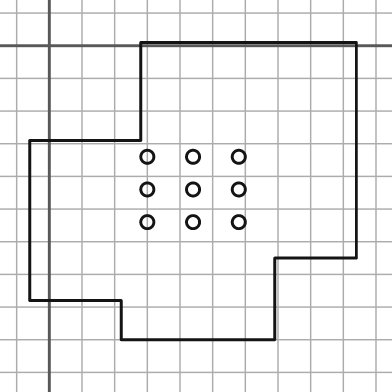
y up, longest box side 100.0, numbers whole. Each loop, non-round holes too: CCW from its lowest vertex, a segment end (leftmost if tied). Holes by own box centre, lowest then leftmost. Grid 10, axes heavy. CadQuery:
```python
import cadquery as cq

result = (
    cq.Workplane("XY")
    .moveTo(22.0, -90.0)
    .lineTo(69.0, -90.0)
    .lineTo(69.0, -65.0)
    .lineTo(94.0, -65.0)
    .lineTo(94.0, 1.0)
    .lineTo(28.0, 1.0)
    .lineTo(28.0, -29.0)
    .lineTo(-6.0, -29.0)
    .lineTo(-6.0, -78.0)
    .lineTo(22.0, -78.0)
    .close()
    .moveTo(30.0, -54.0)
    .circle(2.0)
    .moveTo(44.0, -54.0)
    .circle(2.0)
    .moveTo(58.0, -54.0)
    .circle(2.0)
    .moveTo(30.0, -44.0)
    .circle(2.0)
    .moveTo(44.0, -44.0)
    .circle(2.0)
    .moveTo(58.0, -44.0)
    .circle(2.0)
    .moveTo(30.0, -34.0)
    .circle(2.0)
    .moveTo(44.0, -34.0)
    .circle(2.0)
    .moveTo(58.0, -34.0)
    .circle(2.0)
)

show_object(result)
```